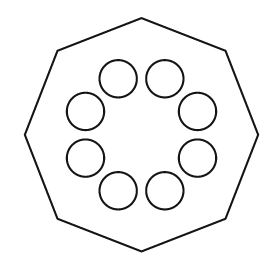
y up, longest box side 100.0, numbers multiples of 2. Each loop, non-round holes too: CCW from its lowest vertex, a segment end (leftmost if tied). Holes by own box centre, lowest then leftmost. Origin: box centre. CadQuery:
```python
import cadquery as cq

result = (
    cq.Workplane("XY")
    .moveTo(0.0, -50.0)
    .lineTo(36.0, -36.0)
    .lineTo(50.0, 0.0)
    .lineTo(36.0, 36.0)
    .lineTo(0.0, 50.0)
    .lineTo(-36.0, 36.0)
    .lineTo(-50.0, 0.0)
    .lineTo(-36.0, -36.0)
    .close()
    .moveTo(-10.0, -24.0)
    .circle(8.0)
    .moveTo(10.0, -24.0)
    .circle(8.0)
    .moveTo(-24.0, -10.0)
    .circle(8.0)
    .moveTo(24.0, -10.0)
    .circle(8.0)
    .moveTo(-24.0, 10.0)
    .circle(8.0)
    .moveTo(24.0, 10.0)
    .circle(8.0)
    .moveTo(-10.0, 24.0)
    .circle(8.0)
    .moveTo(10.0, 24.0)
    .circle(8.0)
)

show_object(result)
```